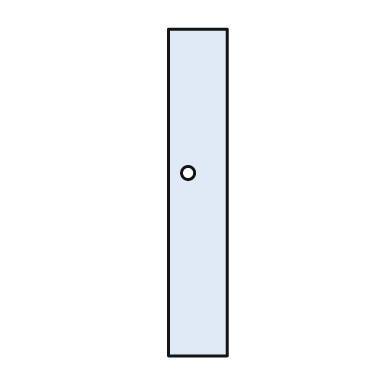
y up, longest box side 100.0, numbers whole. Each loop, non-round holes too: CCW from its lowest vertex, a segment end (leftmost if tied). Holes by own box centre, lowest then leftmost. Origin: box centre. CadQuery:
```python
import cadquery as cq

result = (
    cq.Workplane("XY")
    .moveTo(-9.0, -50.0)
    .lineTo(9.0, -50.0)
    .lineTo(9.0, 50.0)
    .lineTo(-9.0, 50.0)
    .close()
    .moveTo(-3.0, 6.0)
    .circle(2.0)
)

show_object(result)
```